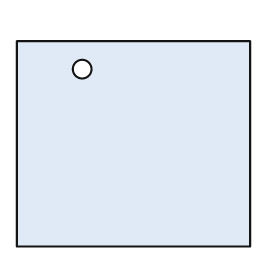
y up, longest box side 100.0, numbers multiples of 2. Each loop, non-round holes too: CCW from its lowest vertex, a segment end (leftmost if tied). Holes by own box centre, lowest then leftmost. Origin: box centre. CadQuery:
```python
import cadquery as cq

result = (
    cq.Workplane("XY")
    .moveTo(-50.0, -44.0)
    .lineTo(50.0, -44.0)
    .lineTo(50.0, 44.0)
    .lineTo(-50.0, 44.0)
    .close()
    .moveTo(-22.0, 32.0)
    .circle(4.0)
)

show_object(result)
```